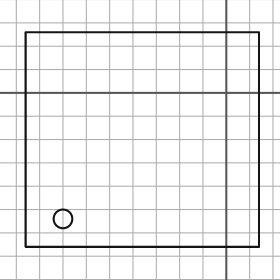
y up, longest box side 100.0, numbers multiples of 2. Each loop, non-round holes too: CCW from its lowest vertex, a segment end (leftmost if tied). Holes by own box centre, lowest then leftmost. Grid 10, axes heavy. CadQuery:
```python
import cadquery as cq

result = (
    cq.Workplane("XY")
    .moveTo(-86.0, -66.0)
    .lineTo(14.0, -66.0)
    .lineTo(14.0, 26.0)
    .lineTo(-86.0, 26.0)
    .close()
    .moveTo(-70.0, -54.0)
    .circle(4.0)
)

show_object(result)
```